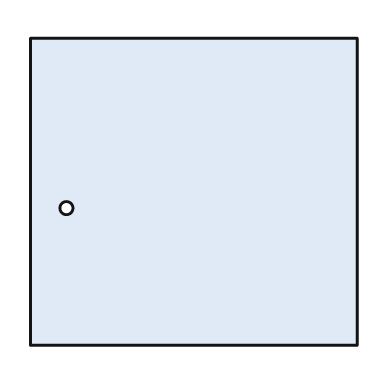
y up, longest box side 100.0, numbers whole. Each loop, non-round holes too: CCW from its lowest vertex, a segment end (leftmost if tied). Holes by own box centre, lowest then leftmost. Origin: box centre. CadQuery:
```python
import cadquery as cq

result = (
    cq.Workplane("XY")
    .moveTo(-50.0, -47.0)
    .lineTo(50.0, -47.0)
    .lineTo(50.0, 47.0)
    .lineTo(-50.0, 47.0)
    .close()
    .moveTo(-39.0, -5.0)
    .circle(2.0)
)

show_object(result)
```